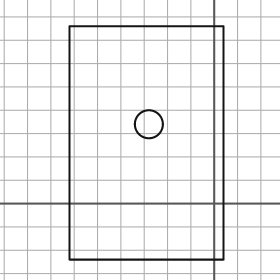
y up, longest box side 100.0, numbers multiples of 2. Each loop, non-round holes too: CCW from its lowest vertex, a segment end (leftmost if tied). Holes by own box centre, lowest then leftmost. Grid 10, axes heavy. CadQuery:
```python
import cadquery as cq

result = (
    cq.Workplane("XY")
    .moveTo(-62.0, -24.0)
    .lineTo(4.0, -24.0)
    .lineTo(4.0, 76.0)
    .lineTo(-62.0, 76.0)
    .close()
    .moveTo(-28.0, 34.0)
    .circle(6.0)
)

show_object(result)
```